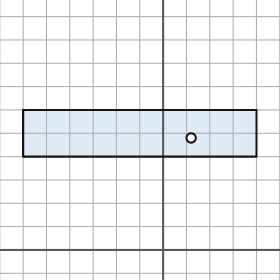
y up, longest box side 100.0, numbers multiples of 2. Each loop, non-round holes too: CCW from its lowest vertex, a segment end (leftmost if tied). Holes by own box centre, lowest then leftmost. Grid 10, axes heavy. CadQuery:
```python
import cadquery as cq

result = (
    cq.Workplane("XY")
    .moveTo(-60.0, 40.0)
    .lineTo(40.0, 40.0)
    .lineTo(40.0, 60.0)
    .lineTo(-60.0, 60.0)
    .close()
    .moveTo(12.0, 48.0)
    .circle(2.0)
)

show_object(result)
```